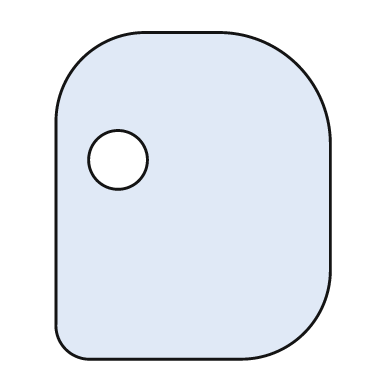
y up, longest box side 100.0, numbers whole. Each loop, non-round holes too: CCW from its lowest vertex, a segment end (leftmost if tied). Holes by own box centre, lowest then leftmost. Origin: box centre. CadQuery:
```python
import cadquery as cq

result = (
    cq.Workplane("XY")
    .moveTo(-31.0, -50.0)
    .lineTo(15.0, -50.0)
    .threePointArc((34.0, -42.0), (42.0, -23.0))
    .lineTo(42.0, 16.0)
    .threePointArc((32.0, 40.0), (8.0, 50.0))
    .lineTo(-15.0, 50.0)
    .threePointArc((-34.0, 42.0), (-42.0, 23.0))
    .lineTo(-42.0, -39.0)
    .threePointArc((-39.0, -47.0), (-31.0, -50.0))
    .close()
    .moveTo(-23.0, 11.0)
    .circle(9.0)
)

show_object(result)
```